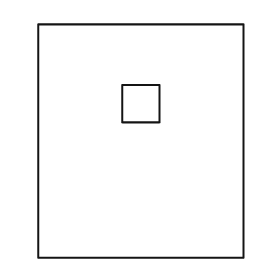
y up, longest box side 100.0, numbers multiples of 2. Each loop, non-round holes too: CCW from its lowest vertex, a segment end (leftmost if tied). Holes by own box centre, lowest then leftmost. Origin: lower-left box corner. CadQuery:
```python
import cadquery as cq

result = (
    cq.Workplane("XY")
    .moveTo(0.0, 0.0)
    .lineTo(88.0, 0.0)
    .lineTo(88.0, 100.0)
    .lineTo(0.0, 100.0)
    .close()
    .moveTo(36.0, 58.0)
    .lineTo(52.0, 58.0)
    .lineTo(52.0, 74.0)
    .lineTo(36.0, 74.0)
    .close()
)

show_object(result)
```